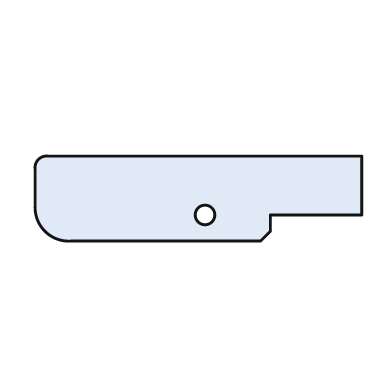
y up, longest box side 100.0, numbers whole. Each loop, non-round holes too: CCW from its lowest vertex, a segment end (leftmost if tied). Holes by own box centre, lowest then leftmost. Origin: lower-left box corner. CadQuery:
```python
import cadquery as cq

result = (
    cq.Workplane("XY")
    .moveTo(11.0, 0.0)
    .lineTo(69.0, 0.0)
    .lineTo(72.0, 3.0)
    .lineTo(72.0, 8.0)
    .lineTo(100.0, 8.0)
    .lineTo(100.0, 26.0)
    .lineTo(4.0, 26.0)
    .threePointArc((1.0, 25.0), (0.0, 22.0))
    .lineTo(0.0, 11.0)
    .threePointArc((3.0, 3.0), (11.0, 0.0))
    .close()
    .moveTo(52.0, 8.0)
    .circle(3.0)
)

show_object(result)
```